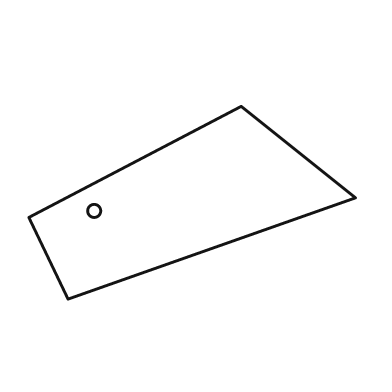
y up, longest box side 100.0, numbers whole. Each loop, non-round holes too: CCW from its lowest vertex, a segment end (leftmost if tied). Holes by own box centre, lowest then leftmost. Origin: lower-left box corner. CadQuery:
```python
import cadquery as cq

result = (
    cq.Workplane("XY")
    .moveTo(12.0, 0.0)
    .lineTo(100.0, 31.0)
    .lineTo(65.0, 59.0)
    .lineTo(0.0, 25.0)
    .close()
    .moveTo(20.0, 27.0)
    .circle(2.0)
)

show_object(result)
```